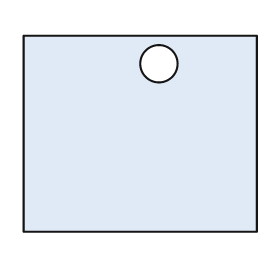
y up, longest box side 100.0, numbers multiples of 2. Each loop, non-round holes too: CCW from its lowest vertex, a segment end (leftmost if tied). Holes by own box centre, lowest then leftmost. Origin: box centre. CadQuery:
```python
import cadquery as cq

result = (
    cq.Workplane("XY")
    .moveTo(-50.0, -42.0)
    .lineTo(50.0, -42.0)
    .lineTo(50.0, 42.0)
    .lineTo(-50.0, 42.0)
    .close()
    .moveTo(8.0, 30.0)
    .circle(8.0)
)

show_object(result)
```